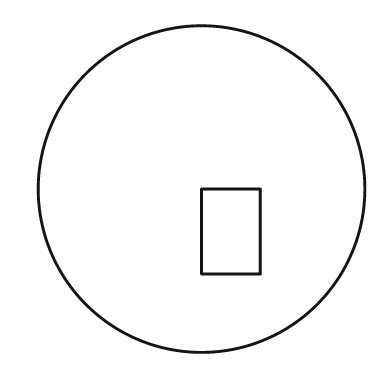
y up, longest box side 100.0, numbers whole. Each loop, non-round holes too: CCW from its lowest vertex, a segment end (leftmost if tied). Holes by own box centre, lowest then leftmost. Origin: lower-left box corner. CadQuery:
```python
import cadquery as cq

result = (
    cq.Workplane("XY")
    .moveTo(50.0, 50.0)
    .circle(50.0)
    .moveTo(50.0, 24.0)
    .lineTo(68.0, 24.0)
    .lineTo(68.0, 50.0)
    .lineTo(50.0, 50.0)
    .close()
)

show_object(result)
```